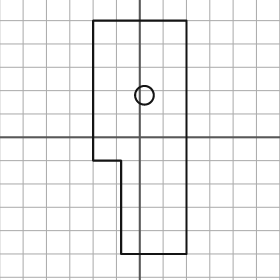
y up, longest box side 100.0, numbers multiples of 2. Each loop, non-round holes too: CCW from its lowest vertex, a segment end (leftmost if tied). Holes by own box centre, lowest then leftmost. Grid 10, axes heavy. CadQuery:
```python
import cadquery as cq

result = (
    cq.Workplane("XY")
    .moveTo(-8.0, -50.0)
    .lineTo(20.0, -50.0)
    .lineTo(20.0, 50.0)
    .lineTo(-20.0, 50.0)
    .lineTo(-20.0, -10.0)
    .lineTo(-8.0, -10.0)
    .close()
    .moveTo(2.0, 18.0)
    .circle(4.0)
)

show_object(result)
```